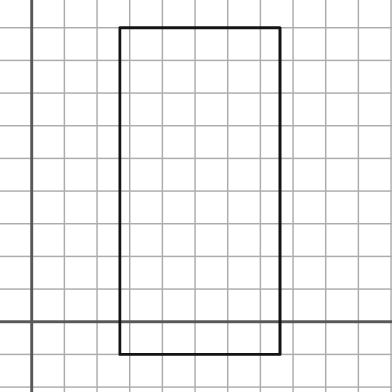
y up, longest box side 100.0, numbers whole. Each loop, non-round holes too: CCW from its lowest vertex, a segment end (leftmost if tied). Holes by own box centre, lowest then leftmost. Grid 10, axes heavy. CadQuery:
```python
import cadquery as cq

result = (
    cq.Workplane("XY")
    .moveTo(27.0, -10.0)
    .lineTo(76.0, -10.0)
    .lineTo(76.0, 90.0)
    .lineTo(27.0, 90.0)
    .close()
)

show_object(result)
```